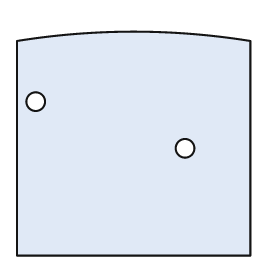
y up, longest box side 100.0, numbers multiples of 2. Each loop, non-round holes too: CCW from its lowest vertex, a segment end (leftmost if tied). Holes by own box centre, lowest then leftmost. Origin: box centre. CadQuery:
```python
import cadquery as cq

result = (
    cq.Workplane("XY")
    .moveTo(-50.0, -48.0)
    .lineTo(50.0, -48.0)
    .lineTo(50.0, 44.0)
    .threePointArc((0.0, 48.0), (-50.0, 44.0))
    .close()
    .moveTo(22.0, -2.0)
    .circle(4.0)
    .moveTo(-42.0, 18.0)
    .circle(4.0)
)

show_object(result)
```